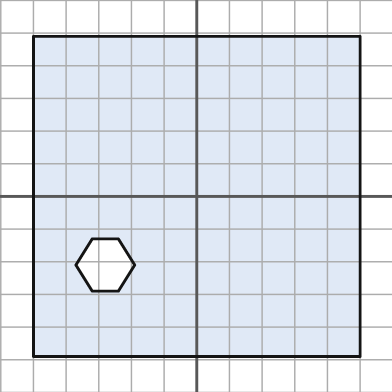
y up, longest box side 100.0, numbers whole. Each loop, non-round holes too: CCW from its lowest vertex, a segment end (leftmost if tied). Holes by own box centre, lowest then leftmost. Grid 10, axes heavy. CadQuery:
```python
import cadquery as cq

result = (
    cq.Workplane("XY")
    .moveTo(-50.0, -49.0)
    .lineTo(50.0, -49.0)
    .lineTo(50.0, 49.0)
    .lineTo(-50.0, 49.0)
    .close()
    .moveTo(-32.0, -29.0)
    .lineTo(-24.0, -29.0)
    .lineTo(-19.0, -21.0)
    .lineTo(-24.0, -13.0)
    .lineTo(-32.0, -13.0)
    .lineTo(-37.0, -21.0)
    .close()
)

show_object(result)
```